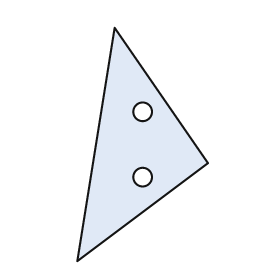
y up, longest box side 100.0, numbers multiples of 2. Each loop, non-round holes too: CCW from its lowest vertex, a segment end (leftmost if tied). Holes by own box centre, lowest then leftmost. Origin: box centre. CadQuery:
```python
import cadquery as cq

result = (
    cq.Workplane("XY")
    .moveTo(-28.0, -50.0)
    .lineTo(28.0, -8.0)
    .lineTo(-12.0, 50.0)
    .close()
    .moveTo(0.0, -14.0)
    .circle(4.0)
    .moveTo(0.0, 14.0)
    .circle(4.0)
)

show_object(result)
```